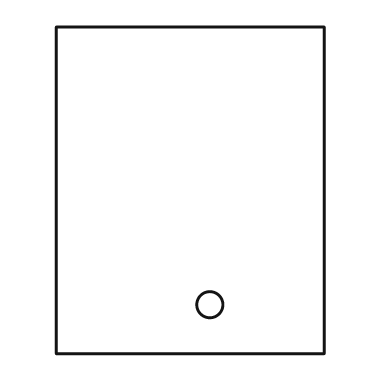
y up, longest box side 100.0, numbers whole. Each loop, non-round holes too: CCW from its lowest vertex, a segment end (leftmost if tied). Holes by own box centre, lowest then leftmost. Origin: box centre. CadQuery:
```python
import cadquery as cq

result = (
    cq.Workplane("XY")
    .moveTo(-41.0, -50.0)
    .lineTo(41.0, -50.0)
    .lineTo(41.0, 50.0)
    .lineTo(-41.0, 50.0)
    .close()
    .moveTo(6.0, -35.0)
    .circle(4.0)
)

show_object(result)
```